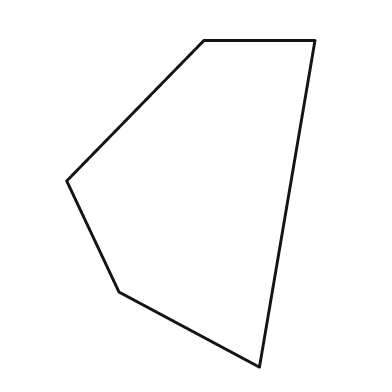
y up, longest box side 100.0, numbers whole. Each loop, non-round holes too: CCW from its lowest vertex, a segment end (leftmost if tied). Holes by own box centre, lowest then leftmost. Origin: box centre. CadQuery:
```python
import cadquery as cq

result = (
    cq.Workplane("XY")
    .moveTo(21.0, -50.0)
    .lineTo(38.0, 50.0)
    .lineTo(4.0, 50.0)
    .lineTo(-38.0, 7.0)
    .lineTo(-22.0, -27.0)
    .close()
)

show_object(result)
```